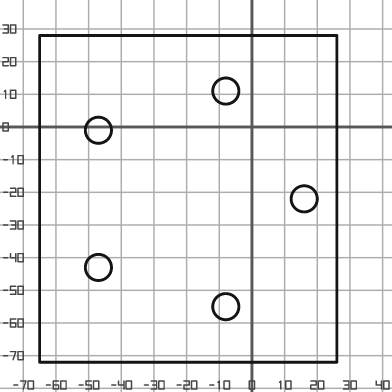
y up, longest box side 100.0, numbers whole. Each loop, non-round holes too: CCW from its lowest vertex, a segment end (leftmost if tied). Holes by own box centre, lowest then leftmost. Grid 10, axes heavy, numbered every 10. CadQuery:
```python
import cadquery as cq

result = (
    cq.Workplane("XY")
    .moveTo(-65.0, -72.0)
    .lineTo(26.0, -72.0)
    .lineTo(26.0, 28.0)
    .lineTo(-65.0, 28.0)
    .close()
    .moveTo(-8.0, -55.0)
    .circle(4.0)
    .moveTo(-47.0, -43.0)
    .circle(4.0)
    .moveTo(16.0, -22.0)
    .circle(4.0)
    .moveTo(-47.0, -1.0)
    .circle(4.0)
    .moveTo(-8.0, 11.0)
    .circle(4.0)
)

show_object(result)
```